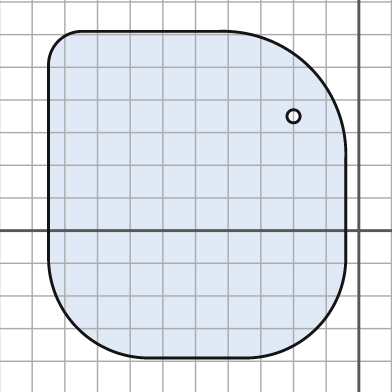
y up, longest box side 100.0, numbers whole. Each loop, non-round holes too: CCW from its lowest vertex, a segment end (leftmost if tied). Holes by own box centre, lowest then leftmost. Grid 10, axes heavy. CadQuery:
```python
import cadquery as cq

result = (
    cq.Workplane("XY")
    .moveTo(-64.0, -39.0)
    .lineTo(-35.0, -39.0)
    .threePointArc((-13.0, -30.0), (-4.0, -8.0))
    .lineTo(-4.0, 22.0)
    .threePointArc((-15.0, 50.0), (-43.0, 61.0))
    .lineTo(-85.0, 61.0)
    .threePointArc((-92.0, 58.0), (-95.0, 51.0))
    .lineTo(-95.0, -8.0)
    .threePointArc((-86.0, -30.0), (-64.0, -39.0))
    .close()
    .moveTo(-20.0, 35.0)
    .circle(2.0)
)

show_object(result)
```